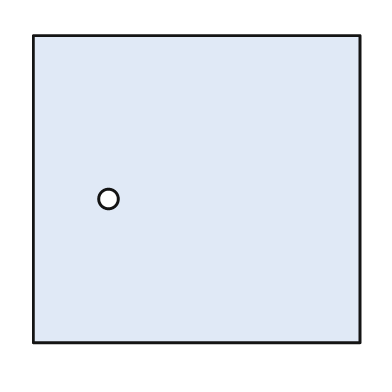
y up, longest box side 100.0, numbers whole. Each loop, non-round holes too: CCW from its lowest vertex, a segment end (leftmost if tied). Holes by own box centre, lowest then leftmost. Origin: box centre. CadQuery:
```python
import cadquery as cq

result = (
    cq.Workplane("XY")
    .moveTo(-50.0, -47.0)
    .lineTo(50.0, -47.0)
    .lineTo(50.0, 47.0)
    .lineTo(-50.0, 47.0)
    .close()
    .moveTo(-27.0, -3.0)
    .circle(3.0)
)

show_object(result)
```